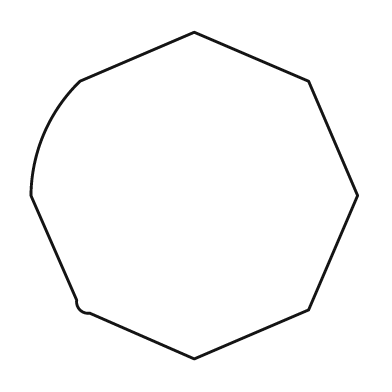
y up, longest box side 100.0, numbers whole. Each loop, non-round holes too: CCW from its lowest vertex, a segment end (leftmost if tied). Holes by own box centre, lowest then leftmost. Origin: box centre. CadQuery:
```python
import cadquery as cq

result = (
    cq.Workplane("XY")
    .moveTo(0.0, -50.0)
    .lineTo(35.0, -35.0)
    .lineTo(50.0, 0.0)
    .lineTo(35.0, 35.0)
    .lineTo(0.0, 50.0)
    .lineTo(-35.0, 35.0)
    .threePointArc((-46.0, 19.0), (-50.0, 0.0))
    .lineTo(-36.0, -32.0)
    .threePointArc((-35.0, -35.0), (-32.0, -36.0))
    .close()
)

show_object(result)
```